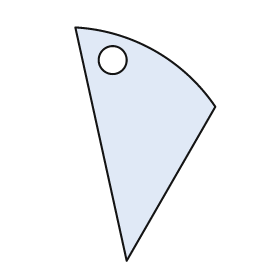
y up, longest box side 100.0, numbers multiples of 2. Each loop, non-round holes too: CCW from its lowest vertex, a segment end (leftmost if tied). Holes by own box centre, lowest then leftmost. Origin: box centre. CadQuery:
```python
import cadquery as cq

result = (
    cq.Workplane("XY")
    .moveTo(-8.0, -50.0)
    .lineTo(30.0, 16.0)
    .threePointArc((4.0, 40.0), (-30.0, 50.0))
    .close()
    .moveTo(-14.0, 36.0)
    .circle(6.0)
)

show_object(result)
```